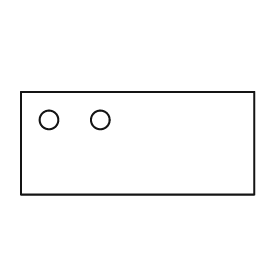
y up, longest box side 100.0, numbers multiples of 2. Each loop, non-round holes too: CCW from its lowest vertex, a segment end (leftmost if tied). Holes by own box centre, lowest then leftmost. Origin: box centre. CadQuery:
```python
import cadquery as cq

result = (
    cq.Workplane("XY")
    .moveTo(-50.0, -22.0)
    .lineTo(50.0, -22.0)
    .lineTo(50.0, 22.0)
    .lineTo(-50.0, 22.0)
    .close()
    .moveTo(-38.0, 10.0)
    .circle(4.0)
    .moveTo(-16.0, 10.0)
    .circle(4.0)
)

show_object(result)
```